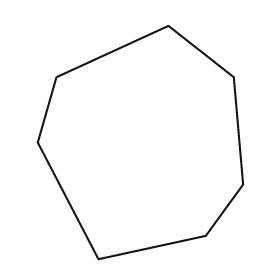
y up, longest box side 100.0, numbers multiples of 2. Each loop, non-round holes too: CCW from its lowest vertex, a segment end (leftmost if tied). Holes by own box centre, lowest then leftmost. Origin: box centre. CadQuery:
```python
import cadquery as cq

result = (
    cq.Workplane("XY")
    .moveTo(-18.0, -50.0)
    .lineTo(28.0, -40.0)
    .lineTo(44.0, -18.0)
    .lineTo(40.0, 28.0)
    .lineTo(12.0, 50.0)
    .lineTo(-36.0, 28.0)
    .lineTo(-44.0, 0.0)
    .close()
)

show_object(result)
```